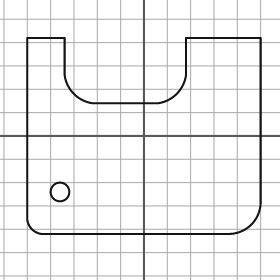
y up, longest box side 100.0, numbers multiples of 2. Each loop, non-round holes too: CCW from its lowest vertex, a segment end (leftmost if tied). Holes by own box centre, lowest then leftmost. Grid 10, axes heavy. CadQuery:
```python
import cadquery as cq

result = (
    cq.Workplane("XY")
    .moveTo(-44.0, -42.0)
    .lineTo(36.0, -42.0)
    .threePointArc((46.0, -38.0), (50.0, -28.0))
    .lineTo(50.0, 42.0)
    .lineTo(18.0, 42.0)
    .lineTo(18.0, 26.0)
    .threePointArc((14.0, 18.0), (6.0, 14.0))
    .lineTo(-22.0, 14.0)
    .threePointArc((-30.0, 18.0), (-34.0, 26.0))
    .lineTo(-34.0, 42.0)
    .lineTo(-50.0, 42.0)
    .lineTo(-50.0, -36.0)
    .threePointArc((-48.0, -40.0), (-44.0, -42.0))
    .close()
    .moveTo(-36.0, -24.0)
    .circle(4.0)
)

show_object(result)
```